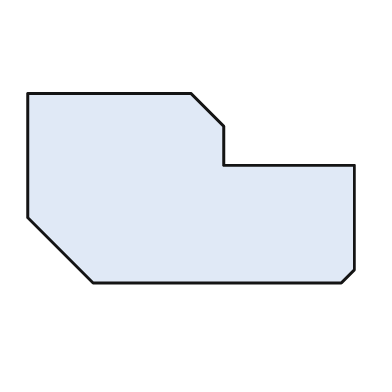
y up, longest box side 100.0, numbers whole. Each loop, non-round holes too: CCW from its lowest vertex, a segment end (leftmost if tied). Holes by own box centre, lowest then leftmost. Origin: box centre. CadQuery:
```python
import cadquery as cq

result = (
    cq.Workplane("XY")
    .moveTo(-30.0, -29.0)
    .lineTo(46.0, -29.0)
    .lineTo(50.0, -25.0)
    .lineTo(50.0, 7.0)
    .lineTo(10.0, 7.0)
    .lineTo(10.0, 19.0)
    .lineTo(0.0, 29.0)
    .lineTo(-50.0, 29.0)
    .lineTo(-50.0, -9.0)
    .close()
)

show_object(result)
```